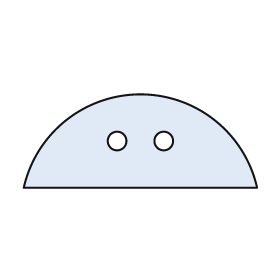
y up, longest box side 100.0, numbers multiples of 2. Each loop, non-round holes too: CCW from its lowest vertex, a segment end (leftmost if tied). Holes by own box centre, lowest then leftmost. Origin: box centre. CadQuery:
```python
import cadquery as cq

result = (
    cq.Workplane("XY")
    .moveTo(-50.0, -20.0)
    .lineTo(50.0, -20.0)
    .threePointArc((0.0, 20.0), (-50.0, -20.0))
    .close()
    .moveTo(-10.0, 0.0)
    .circle(4.0)
    .moveTo(10.0, 0.0)
    .circle(4.0)
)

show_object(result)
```